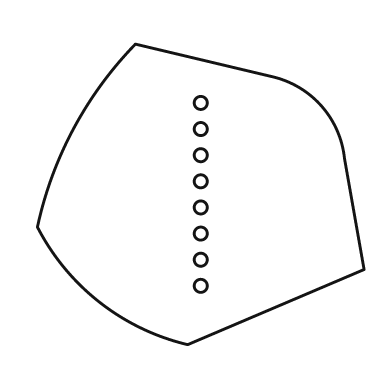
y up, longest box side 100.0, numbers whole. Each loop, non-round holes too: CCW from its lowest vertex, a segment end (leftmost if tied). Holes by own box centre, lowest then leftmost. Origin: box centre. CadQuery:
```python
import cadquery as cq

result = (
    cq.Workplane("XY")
    .moveTo(-4.0, -46.0)
    .lineTo(50.0, -23.0)
    .lineTo(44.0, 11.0)
    .threePointArc((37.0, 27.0), (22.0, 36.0))
    .lineTo(-20.0, 46.0)
    .threePointArc((-39.0, 20.0), (-50.0, -10.0))
    .threePointArc((-31.0, -33.0), (-4.0, -46.0))
    .close()
    .moveTo(0.0, -28.0)
    .circle(2.0)
    .moveTo(0.0, -20.0)
    .circle(2.0)
    .moveTo(0.0, -12.0)
    .circle(2.0)
    .moveTo(0.0, -4.0)
    .circle(2.0)
    .moveTo(0.0, 4.0)
    .circle(2.0)
    .moveTo(0.0, 12.0)
    .circle(2.0)
    .moveTo(0.0, 20.0)
    .circle(2.0)
    .moveTo(0.0, 28.0)
    .circle(2.0)
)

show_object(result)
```